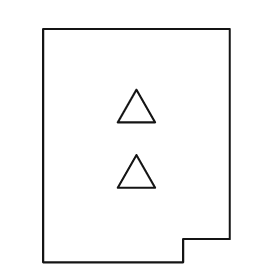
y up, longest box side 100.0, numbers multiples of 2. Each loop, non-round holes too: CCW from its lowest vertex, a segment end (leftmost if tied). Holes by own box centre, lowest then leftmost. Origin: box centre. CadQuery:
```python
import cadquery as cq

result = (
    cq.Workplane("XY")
    .moveTo(-40.0, -50.0)
    .lineTo(20.0, -50.0)
    .lineTo(20.0, -40.0)
    .lineTo(40.0, -40.0)
    .lineTo(40.0, 50.0)
    .lineTo(-40.0, 50.0)
    .close()
    .moveTo(-8.0, -18.0)
    .lineTo(8.0, -18.0)
    .lineTo(0.0, -4.0)
    .close()
    .moveTo(-8.0, 10.0)
    .lineTo(8.0, 10.0)
    .lineTo(0.0, 24.0)
    .close()
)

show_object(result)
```